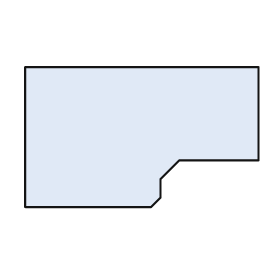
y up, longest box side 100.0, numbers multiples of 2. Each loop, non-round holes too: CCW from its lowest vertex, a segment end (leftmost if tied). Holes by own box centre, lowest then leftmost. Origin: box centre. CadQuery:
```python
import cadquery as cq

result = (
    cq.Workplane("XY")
    .moveTo(-50.0, -30.0)
    .lineTo(4.0, -30.0)
    .lineTo(8.0, -26.0)
    .lineTo(8.0, -18.0)
    .lineTo(16.0, -10.0)
    .lineTo(50.0, -10.0)
    .lineTo(50.0, 30.0)
    .lineTo(-50.0, 30.0)
    .close()
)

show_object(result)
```